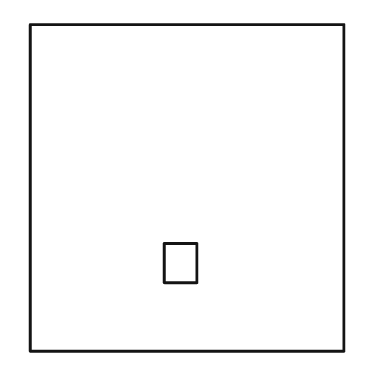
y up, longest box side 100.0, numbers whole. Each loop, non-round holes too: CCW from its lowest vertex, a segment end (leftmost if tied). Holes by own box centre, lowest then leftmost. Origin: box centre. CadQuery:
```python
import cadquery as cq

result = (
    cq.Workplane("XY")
    .moveTo(-48.0, -50.0)
    .lineTo(48.0, -50.0)
    .lineTo(48.0, 50.0)
    .lineTo(-48.0, 50.0)
    .close()
    .moveTo(-7.0, -29.0)
    .lineTo(3.0, -29.0)
    .lineTo(3.0, -17.0)
    .lineTo(-7.0, -17.0)
    .close()
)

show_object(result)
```